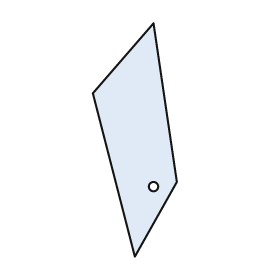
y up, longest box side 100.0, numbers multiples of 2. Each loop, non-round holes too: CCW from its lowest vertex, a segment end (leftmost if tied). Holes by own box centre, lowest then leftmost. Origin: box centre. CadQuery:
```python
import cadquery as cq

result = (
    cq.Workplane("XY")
    .moveTo(0.0, -50.0)
    .lineTo(18.0, -18.0)
    .lineTo(8.0, 50.0)
    .lineTo(-18.0, 20.0)
    .close()
    .moveTo(8.0, -20.0)
    .circle(2.0)
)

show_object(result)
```